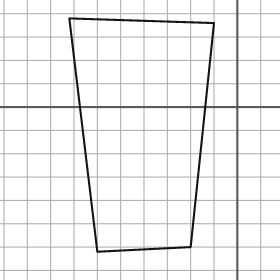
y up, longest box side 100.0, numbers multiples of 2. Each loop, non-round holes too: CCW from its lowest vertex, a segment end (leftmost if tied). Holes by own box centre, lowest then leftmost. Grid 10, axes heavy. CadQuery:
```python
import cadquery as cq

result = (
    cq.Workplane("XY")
    .moveTo(-60.0, -62.0)
    .lineTo(-20.0, -60.0)
    .lineTo(-10.0, 36.0)
    .lineTo(-72.0, 38.0)
    .close()
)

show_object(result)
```